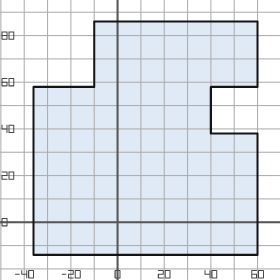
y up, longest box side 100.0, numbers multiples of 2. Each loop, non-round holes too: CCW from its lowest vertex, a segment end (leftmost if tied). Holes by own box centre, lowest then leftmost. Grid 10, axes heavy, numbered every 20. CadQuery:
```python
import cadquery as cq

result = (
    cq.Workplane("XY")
    .moveTo(-36.0, -14.0)
    .lineTo(60.0, -14.0)
    .lineTo(60.0, 38.0)
    .lineTo(40.0, 38.0)
    .lineTo(40.0, 58.0)
    .lineTo(60.0, 58.0)
    .lineTo(60.0, 86.0)
    .lineTo(-10.0, 86.0)
    .lineTo(-10.0, 58.0)
    .lineTo(-36.0, 58.0)
    .close()
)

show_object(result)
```